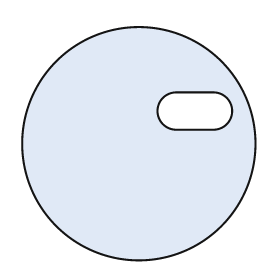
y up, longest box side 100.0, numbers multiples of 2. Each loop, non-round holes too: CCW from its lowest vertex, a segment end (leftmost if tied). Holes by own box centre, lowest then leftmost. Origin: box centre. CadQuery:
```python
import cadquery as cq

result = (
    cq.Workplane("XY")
    .moveTo(0.0, 0.0)
    .circle(50.0)
    .moveTo(16.0, 6.0)
    .lineTo(32.0, 6.0)
    .threePointArc((40.0, 14.0), (32.0, 22.0))
    .lineTo(16.0, 22.0)
    .threePointArc((8.0, 14.0), (16.0, 6.0))
    .close()
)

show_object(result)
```